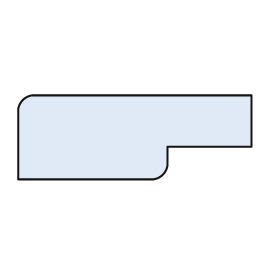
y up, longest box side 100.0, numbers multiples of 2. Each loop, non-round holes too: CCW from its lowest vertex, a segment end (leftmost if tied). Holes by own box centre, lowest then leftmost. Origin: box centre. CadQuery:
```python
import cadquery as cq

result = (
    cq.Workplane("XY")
    .moveTo(-50.0, -18.0)
    .lineTo(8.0, -18.0)
    .threePointArc((12.0, -16.0), (14.0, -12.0))
    .lineTo(14.0, -4.0)
    .lineTo(50.0, -4.0)
    .lineTo(50.0, 18.0)
    .lineTo(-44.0, 18.0)
    .threePointArc((-48.0, 16.0), (-50.0, 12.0))
    .close()
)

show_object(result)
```